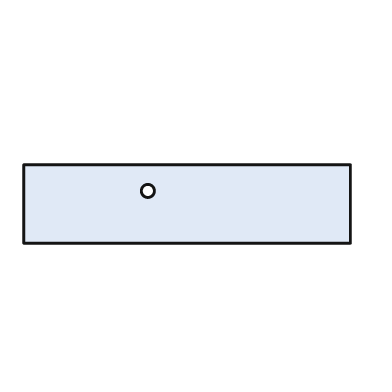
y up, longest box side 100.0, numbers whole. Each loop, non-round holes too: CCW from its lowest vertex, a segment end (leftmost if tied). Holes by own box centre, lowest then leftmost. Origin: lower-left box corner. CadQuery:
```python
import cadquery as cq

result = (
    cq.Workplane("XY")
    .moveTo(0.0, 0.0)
    .lineTo(100.0, 0.0)
    .lineTo(100.0, 24.0)
    .lineTo(0.0, 24.0)
    .close()
    .moveTo(38.0, 16.0)
    .circle(2.0)
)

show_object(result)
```